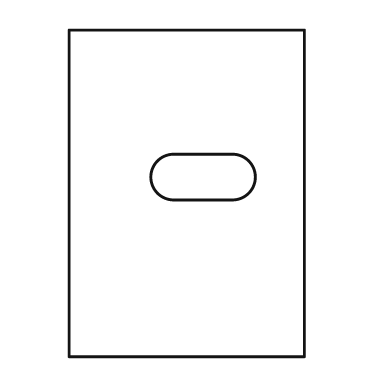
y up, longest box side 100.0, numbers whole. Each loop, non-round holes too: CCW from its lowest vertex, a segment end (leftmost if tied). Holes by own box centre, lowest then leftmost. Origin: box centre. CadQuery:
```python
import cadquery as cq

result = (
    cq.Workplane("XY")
    .moveTo(-36.0, -50.0)
    .lineTo(36.0, -50.0)
    .lineTo(36.0, 50.0)
    .lineTo(-36.0, 50.0)
    .close()
    .moveTo(-4.0, -2.0)
    .lineTo(14.0, -2.0)
    .threePointArc((21.0, 5.0), (14.0, 12.0))
    .lineTo(-4.0, 12.0)
    .threePointArc((-11.0, 5.0), (-4.0, -2.0))
    .close()
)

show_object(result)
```